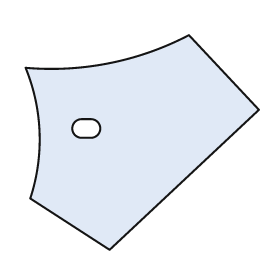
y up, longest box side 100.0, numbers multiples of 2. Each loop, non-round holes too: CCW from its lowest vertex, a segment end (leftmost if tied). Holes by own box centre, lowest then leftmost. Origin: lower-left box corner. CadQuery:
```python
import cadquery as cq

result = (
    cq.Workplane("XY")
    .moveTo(36.0, 0.0)
    .lineTo(100.0, 60.0)
    .lineTo(70.0, 92.0)
    .threePointArc((36.0, 80.0), (0.0, 78.0))
    .threePointArc((6.0, 50.0), (2.0, 22.0))
    .close()
    .moveTo(24.0, 48.0)
    .lineTo(28.0, 48.0)
    .threePointArc((32.0, 52.0), (28.0, 56.0))
    .lineTo(24.0, 56.0)
    .threePointArc((20.0, 52.0), (24.0, 48.0))
    .close()
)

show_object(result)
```